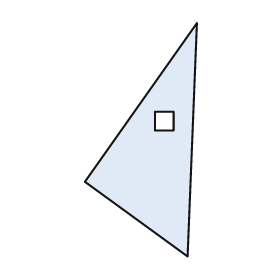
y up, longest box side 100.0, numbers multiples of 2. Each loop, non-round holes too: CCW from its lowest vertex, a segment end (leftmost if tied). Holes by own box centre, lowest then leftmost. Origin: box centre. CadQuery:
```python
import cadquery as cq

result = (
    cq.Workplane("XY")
    .moveTo(20.0, -50.0)
    .lineTo(24.0, 50.0)
    .lineTo(-24.0, -18.0)
    .close()
    .moveTo(6.0, 4.0)
    .lineTo(14.0, 4.0)
    .lineTo(14.0, 12.0)
    .lineTo(6.0, 12.0)
    .close()
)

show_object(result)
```